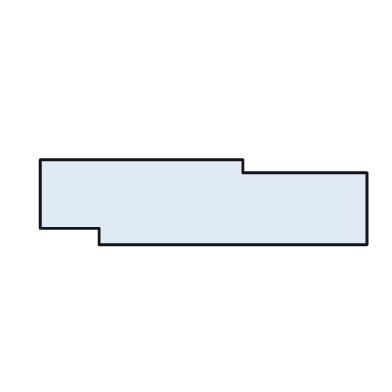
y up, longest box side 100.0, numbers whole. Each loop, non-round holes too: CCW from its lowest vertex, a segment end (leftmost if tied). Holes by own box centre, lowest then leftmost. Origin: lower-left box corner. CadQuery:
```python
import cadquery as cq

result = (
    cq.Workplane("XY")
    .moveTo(18.0, 0.0)
    .lineTo(100.0, 0.0)
    .lineTo(100.0, 22.0)
    .lineTo(62.0, 22.0)
    .lineTo(62.0, 26.0)
    .lineTo(0.0, 26.0)
    .lineTo(0.0, 5.0)
    .lineTo(18.0, 5.0)
    .close()
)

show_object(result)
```